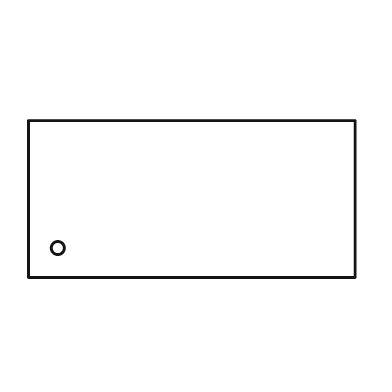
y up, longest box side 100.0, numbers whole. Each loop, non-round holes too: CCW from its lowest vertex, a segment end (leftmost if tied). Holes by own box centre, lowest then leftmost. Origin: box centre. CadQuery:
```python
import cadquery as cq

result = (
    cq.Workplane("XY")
    .moveTo(-50.0, -24.0)
    .lineTo(50.0, -24.0)
    .lineTo(50.0, 24.0)
    .lineTo(-50.0, 24.0)
    .close()
    .moveTo(-41.0, -15.0)
    .circle(2.0)
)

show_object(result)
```